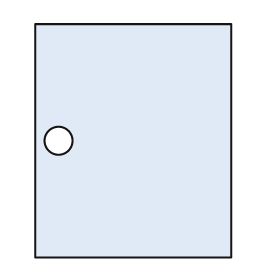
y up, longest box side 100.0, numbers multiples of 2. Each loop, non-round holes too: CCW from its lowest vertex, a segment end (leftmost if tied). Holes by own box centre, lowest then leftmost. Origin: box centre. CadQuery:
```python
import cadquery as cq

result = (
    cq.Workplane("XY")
    .moveTo(-42.0, -50.0)
    .lineTo(42.0, -50.0)
    .lineTo(42.0, 50.0)
    .lineTo(-42.0, 50.0)
    .close()
    .moveTo(-32.0, 0.0)
    .circle(6.0)
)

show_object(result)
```